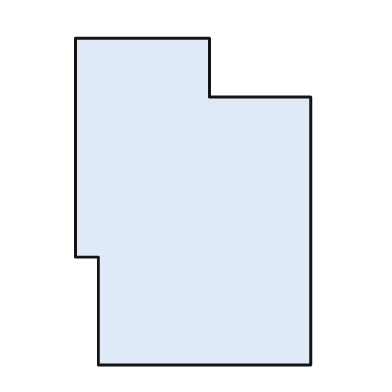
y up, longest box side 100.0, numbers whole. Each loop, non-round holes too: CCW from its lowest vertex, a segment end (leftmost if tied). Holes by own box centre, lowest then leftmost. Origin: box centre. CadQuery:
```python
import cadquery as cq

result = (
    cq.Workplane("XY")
    .moveTo(-29.0, -50.0)
    .lineTo(36.0, -50.0)
    .lineTo(36.0, 32.0)
    .lineTo(5.0, 32.0)
    .lineTo(5.0, 50.0)
    .lineTo(-36.0, 50.0)
    .lineTo(-36.0, -17.0)
    .lineTo(-29.0, -17.0)
    .close()
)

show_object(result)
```